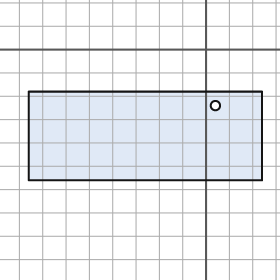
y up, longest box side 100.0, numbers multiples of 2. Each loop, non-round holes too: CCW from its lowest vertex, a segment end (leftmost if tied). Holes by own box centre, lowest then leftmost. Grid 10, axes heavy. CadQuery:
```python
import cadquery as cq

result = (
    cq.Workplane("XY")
    .moveTo(-76.0, -56.0)
    .lineTo(24.0, -56.0)
    .lineTo(24.0, -18.0)
    .lineTo(-76.0, -18.0)
    .close()
    .moveTo(4.0, -24.0)
    .circle(2.0)
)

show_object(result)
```